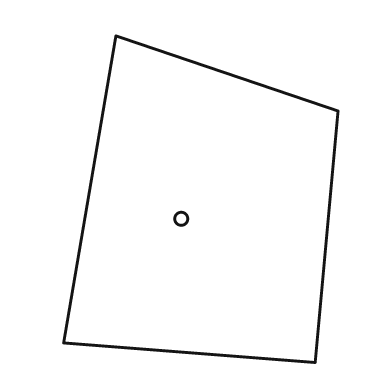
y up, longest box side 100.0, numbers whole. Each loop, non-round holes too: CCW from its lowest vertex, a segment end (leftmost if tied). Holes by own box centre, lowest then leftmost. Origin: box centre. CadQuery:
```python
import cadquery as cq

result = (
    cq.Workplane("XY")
    .moveTo(35.0, -50.0)
    .lineTo(42.0, 27.0)
    .lineTo(-26.0, 50.0)
    .lineTo(-42.0, -44.0)
    .close()
    .moveTo(-6.0, -6.0)
    .circle(2.0)
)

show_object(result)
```